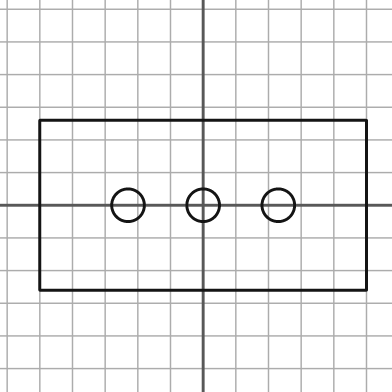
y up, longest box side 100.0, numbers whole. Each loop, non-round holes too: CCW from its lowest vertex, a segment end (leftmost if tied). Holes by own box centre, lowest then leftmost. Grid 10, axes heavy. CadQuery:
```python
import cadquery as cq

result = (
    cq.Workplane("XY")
    .moveTo(-50.0, -26.0)
    .lineTo(50.0, -26.0)
    .lineTo(50.0, 26.0)
    .lineTo(-50.0, 26.0)
    .close()
    .moveTo(-23.0, 0.0)
    .circle(5.0)
    .moveTo(0.0, 0.0)
    .circle(5.0)
    .moveTo(23.0, 0.0)
    .circle(5.0)
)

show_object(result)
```